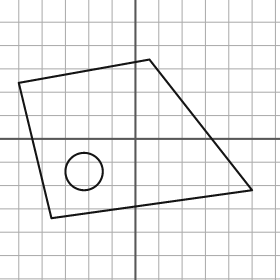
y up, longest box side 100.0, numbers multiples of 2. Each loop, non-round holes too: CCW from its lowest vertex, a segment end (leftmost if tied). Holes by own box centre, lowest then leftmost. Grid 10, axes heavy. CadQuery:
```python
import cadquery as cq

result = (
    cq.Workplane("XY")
    .moveTo(-36.0, -34.0)
    .lineTo(50.0, -22.0)
    .lineTo(6.0, 34.0)
    .lineTo(-50.0, 24.0)
    .close()
    .moveTo(-22.0, -14.0)
    .circle(8.0)
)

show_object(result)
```